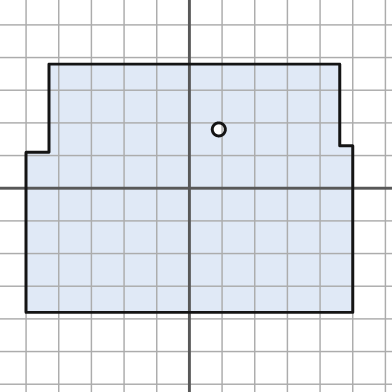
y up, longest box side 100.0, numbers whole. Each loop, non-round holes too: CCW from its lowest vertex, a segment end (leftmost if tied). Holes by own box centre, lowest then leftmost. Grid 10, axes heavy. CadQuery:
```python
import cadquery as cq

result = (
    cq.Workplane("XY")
    .moveTo(-50.0, -38.0)
    .lineTo(50.0, -38.0)
    .lineTo(50.0, 13.0)
    .lineTo(46.0, 13.0)
    .lineTo(46.0, 38.0)
    .lineTo(-43.0, 38.0)
    .lineTo(-43.0, 11.0)
    .lineTo(-50.0, 11.0)
    .close()
    .moveTo(9.0, 18.0)
    .circle(2.0)
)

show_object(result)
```